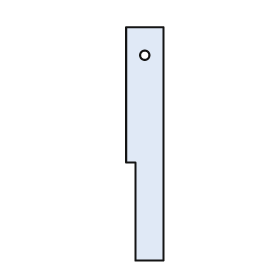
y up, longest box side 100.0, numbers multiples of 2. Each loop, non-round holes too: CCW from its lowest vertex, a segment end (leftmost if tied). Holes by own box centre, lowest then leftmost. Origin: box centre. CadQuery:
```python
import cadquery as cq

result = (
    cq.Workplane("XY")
    .moveTo(-4.0, -50.0)
    .lineTo(8.0, -50.0)
    .lineTo(8.0, 50.0)
    .lineTo(-8.0, 50.0)
    .lineTo(-8.0, -8.0)
    .lineTo(-4.0, -8.0)
    .close()
    .moveTo(0.0, 38.0)
    .circle(2.0)
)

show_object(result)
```